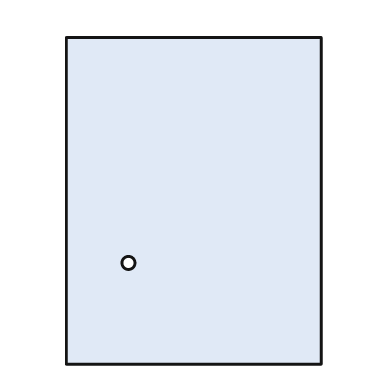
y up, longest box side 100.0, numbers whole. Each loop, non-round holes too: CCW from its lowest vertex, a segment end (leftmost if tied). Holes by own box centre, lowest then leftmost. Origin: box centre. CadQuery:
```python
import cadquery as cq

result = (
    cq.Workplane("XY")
    .moveTo(-39.0, -50.0)
    .lineTo(39.0, -50.0)
    .lineTo(39.0, 50.0)
    .lineTo(-39.0, 50.0)
    .close()
    .moveTo(-20.0, -19.0)
    .circle(2.0)
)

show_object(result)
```